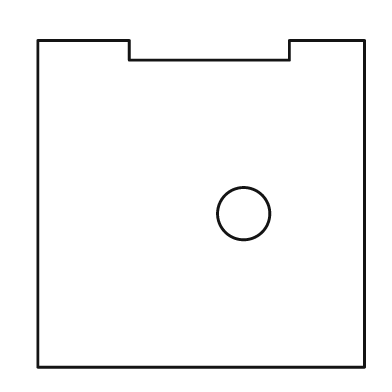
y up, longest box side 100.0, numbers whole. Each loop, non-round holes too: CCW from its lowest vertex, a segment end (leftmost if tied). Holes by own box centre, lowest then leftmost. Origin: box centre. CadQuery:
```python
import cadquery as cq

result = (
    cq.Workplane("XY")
    .moveTo(-50.0, -50.0)
    .lineTo(50.0, -50.0)
    .lineTo(50.0, 50.0)
    .lineTo(27.0, 50.0)
    .lineTo(27.0, 44.0)
    .lineTo(-22.0, 44.0)
    .lineTo(-22.0, 50.0)
    .lineTo(-50.0, 50.0)
    .close()
    .moveTo(13.0, -3.0)
    .circle(8.0)
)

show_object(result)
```